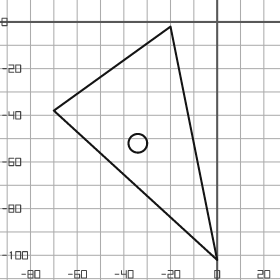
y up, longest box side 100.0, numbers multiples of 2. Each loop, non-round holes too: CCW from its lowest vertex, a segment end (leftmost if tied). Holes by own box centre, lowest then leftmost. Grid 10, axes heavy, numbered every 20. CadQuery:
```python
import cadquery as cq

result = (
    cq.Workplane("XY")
    .moveTo(0.0, -102.0)
    .lineTo(-20.0, -2.0)
    .lineTo(-70.0, -38.0)
    .close()
    .moveTo(-34.0, -52.0)
    .circle(4.0)
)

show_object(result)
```